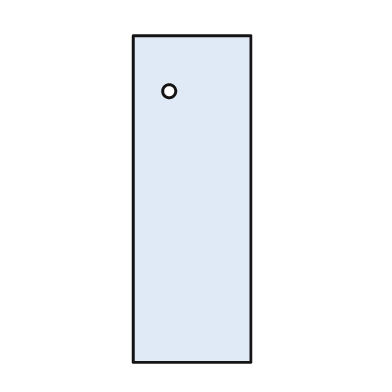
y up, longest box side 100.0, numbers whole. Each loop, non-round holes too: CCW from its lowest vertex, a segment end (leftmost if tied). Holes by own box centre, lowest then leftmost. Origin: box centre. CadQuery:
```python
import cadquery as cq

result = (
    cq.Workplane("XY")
    .moveTo(-18.0, -50.0)
    .lineTo(18.0, -50.0)
    .lineTo(18.0, 50.0)
    .lineTo(-18.0, 50.0)
    .close()
    .moveTo(-7.0, 33.0)
    .circle(2.0)
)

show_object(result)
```